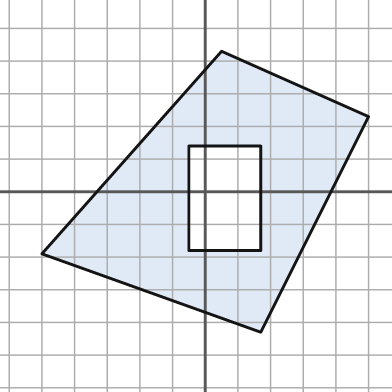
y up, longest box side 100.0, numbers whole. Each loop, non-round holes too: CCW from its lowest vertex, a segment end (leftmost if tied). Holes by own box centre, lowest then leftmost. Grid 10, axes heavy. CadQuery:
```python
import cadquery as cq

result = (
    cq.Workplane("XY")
    .moveTo(17.0, -43.0)
    .lineTo(50.0, 23.0)
    .lineTo(5.0, 43.0)
    .lineTo(-50.0, -19.0)
    .close()
    .moveTo(-5.0, -18.0)
    .lineTo(17.0, -18.0)
    .lineTo(17.0, 14.0)
    .lineTo(-5.0, 14.0)
    .close()
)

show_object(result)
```